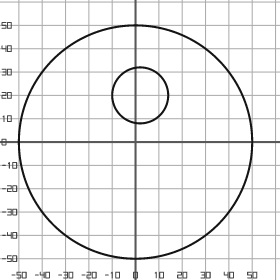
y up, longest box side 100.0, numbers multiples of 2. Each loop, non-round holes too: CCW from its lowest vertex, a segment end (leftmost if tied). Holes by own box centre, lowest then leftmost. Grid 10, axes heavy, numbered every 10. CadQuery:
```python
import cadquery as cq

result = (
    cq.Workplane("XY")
    .moveTo(0.0, 0.0)
    .circle(50.0)
    .moveTo(2.0, 20.0)
    .circle(12.0)
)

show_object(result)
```